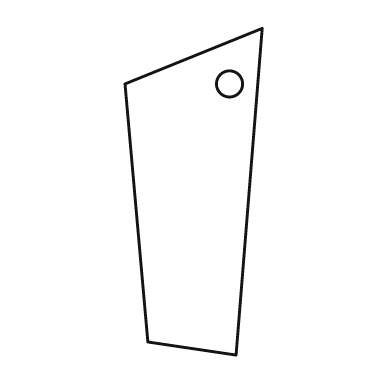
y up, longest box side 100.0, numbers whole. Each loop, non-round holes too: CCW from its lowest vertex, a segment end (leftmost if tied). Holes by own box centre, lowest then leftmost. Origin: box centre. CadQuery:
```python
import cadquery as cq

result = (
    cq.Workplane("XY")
    .moveTo(13.0, -50.0)
    .lineTo(21.0, 50.0)
    .lineTo(-21.0, 33.0)
    .lineTo(-14.0, -46.0)
    .close()
    .moveTo(11.0, 33.0)
    .circle(4.0)
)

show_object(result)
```